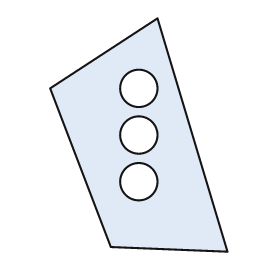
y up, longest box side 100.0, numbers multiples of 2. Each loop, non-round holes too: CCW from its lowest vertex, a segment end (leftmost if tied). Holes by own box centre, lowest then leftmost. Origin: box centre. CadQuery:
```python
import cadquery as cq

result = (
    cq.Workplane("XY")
    .moveTo(38.0, -50.0)
    .lineTo(8.0, 50.0)
    .lineTo(-38.0, 20.0)
    .lineTo(-12.0, -48.0)
    .close()
    .moveTo(0.0, -20.0)
    .circle(8.0)
    .moveTo(0.0, 0.0)
    .circle(8.0)
    .moveTo(0.0, 20.0)
    .circle(8.0)
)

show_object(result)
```